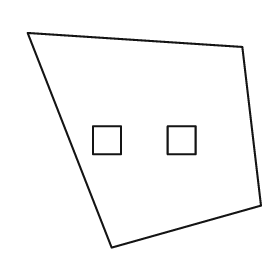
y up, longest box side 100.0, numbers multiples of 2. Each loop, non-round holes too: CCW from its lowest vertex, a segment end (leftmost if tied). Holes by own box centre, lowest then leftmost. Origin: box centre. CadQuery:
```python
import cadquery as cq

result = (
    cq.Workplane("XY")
    .moveTo(-14.0, -46.0)
    .lineTo(50.0, -28.0)
    .lineTo(42.0, 40.0)
    .lineTo(-50.0, 46.0)
    .close()
    .moveTo(-22.0, -6.0)
    .lineTo(-10.0, -6.0)
    .lineTo(-10.0, 6.0)
    .lineTo(-22.0, 6.0)
    .close()
    .moveTo(10.0, -6.0)
    .lineTo(22.0, -6.0)
    .lineTo(22.0, 6.0)
    .lineTo(10.0, 6.0)
    .close()
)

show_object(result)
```